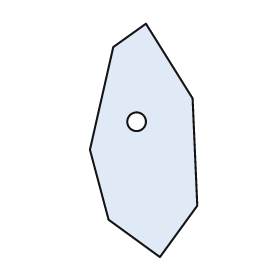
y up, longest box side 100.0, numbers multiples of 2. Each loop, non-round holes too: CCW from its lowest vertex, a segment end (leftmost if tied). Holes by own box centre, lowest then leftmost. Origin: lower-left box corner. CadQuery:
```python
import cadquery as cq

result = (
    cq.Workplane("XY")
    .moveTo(30.0, 0.0)
    .lineTo(46.0, 22.0)
    .lineTo(44.0, 68.0)
    .lineTo(24.0, 100.0)
    .lineTo(10.0, 90.0)
    .lineTo(0.0, 46.0)
    .lineTo(8.0, 16.0)
    .close()
    .moveTo(20.0, 58.0)
    .circle(4.0)
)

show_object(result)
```